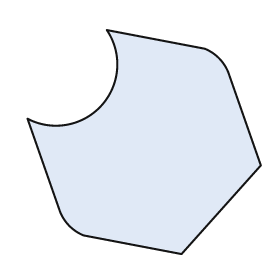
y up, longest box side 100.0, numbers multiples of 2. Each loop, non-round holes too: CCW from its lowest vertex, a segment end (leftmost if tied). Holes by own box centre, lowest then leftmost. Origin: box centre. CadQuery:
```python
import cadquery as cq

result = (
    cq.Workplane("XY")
    .moveTo(16.0, -48.0)
    .lineTo(50.0, -10.0)
    .lineTo(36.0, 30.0)
    .threePointArc((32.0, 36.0), (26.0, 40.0))
    .lineTo(-16.0, 48.0)
    .threePointArc((-18.0, 16.0), (-50.0, 10.0))
    .lineTo(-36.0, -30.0)
    .threePointArc((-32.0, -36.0), (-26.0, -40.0))
    .close()
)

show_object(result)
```